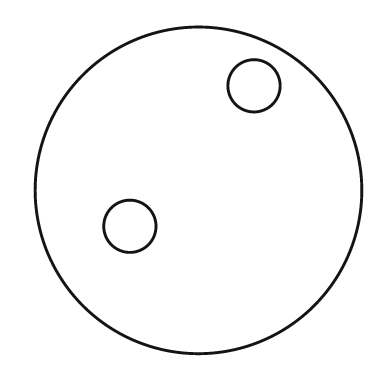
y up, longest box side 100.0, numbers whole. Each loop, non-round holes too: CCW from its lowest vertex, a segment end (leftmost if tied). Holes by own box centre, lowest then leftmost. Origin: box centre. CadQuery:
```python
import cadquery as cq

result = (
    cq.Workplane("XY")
    .moveTo(0.0, 0.0)
    .circle(50.0)
    .moveTo(-21.0, -11.0)
    .circle(8.0)
    .moveTo(17.0, 32.0)
    .circle(8.0)
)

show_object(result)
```